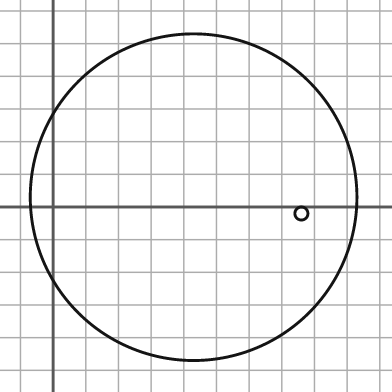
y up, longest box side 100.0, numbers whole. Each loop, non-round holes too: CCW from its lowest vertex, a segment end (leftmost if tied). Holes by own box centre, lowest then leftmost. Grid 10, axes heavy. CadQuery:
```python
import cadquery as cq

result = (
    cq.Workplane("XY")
    .moveTo(43.0, 3.0)
    .circle(50.0)
    .moveTo(76.0, -2.0)
    .circle(2.0)
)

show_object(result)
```